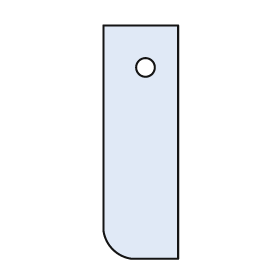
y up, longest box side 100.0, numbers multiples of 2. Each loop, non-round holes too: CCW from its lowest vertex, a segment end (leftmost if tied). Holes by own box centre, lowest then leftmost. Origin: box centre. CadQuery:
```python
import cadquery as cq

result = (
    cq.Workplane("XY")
    .moveTo(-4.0, -50.0)
    .lineTo(16.0, -50.0)
    .lineTo(16.0, 50.0)
    .lineTo(-16.0, 50.0)
    .lineTo(-16.0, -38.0)
    .threePointArc((-12.0, -46.0), (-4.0, -50.0))
    .close()
    .moveTo(2.0, 32.0)
    .circle(4.0)
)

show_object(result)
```